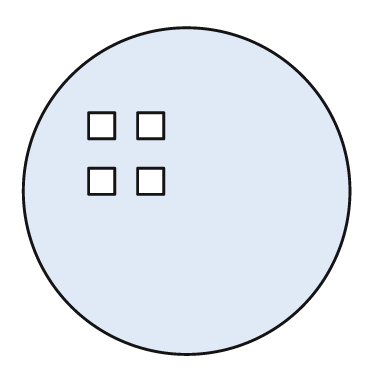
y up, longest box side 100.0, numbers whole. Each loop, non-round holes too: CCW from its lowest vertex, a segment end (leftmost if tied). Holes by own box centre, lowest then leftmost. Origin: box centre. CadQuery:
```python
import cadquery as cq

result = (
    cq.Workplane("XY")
    .moveTo(0.0, 0.0)
    .circle(50.0)
    .moveTo(-30.0, -1.0)
    .lineTo(-22.0, -1.0)
    .lineTo(-22.0, 7.0)
    .lineTo(-30.0, 7.0)
    .close()
    .moveTo(-15.0, -1.0)
    .lineTo(-7.0, -1.0)
    .lineTo(-7.0, 7.0)
    .lineTo(-15.0, 7.0)
    .close()
    .moveTo(-30.0, 16.0)
    .lineTo(-22.0, 16.0)
    .lineTo(-22.0, 24.0)
    .lineTo(-30.0, 24.0)
    .close()
    .moveTo(-15.0, 16.0)
    .lineTo(-7.0, 16.0)
    .lineTo(-7.0, 24.0)
    .lineTo(-15.0, 24.0)
    .close()
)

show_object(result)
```